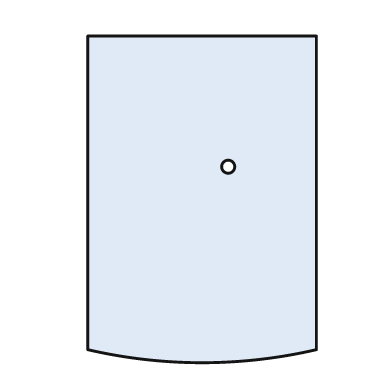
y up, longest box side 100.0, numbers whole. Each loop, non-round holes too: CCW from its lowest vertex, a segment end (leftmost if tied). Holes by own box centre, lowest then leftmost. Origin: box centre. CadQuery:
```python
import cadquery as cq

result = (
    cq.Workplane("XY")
    .moveTo(-35.0, -46.0)
    .threePointArc((0.0, -50.0), (35.0, -46.0))
    .lineTo(35.0, 50.0)
    .lineTo(-35.0, 50.0)
    .close()
    .moveTo(8.0, 10.0)
    .circle(2.0)
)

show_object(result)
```